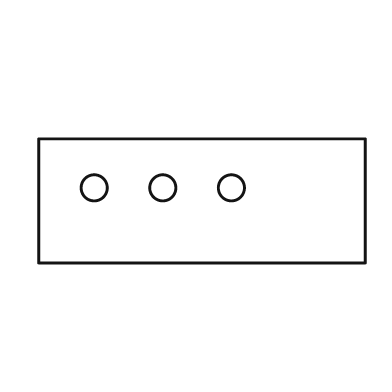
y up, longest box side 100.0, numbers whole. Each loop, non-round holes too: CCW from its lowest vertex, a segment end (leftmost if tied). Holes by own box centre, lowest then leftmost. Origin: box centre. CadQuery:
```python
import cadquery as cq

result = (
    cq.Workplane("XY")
    .moveTo(-50.0, -19.0)
    .lineTo(50.0, -19.0)
    .lineTo(50.0, 19.0)
    .lineTo(-50.0, 19.0)
    .close()
    .moveTo(-33.0, 4.0)
    .circle(4.0)
    .moveTo(-12.0, 4.0)
    .circle(4.0)
    .moveTo(9.0, 4.0)
    .circle(4.0)
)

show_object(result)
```